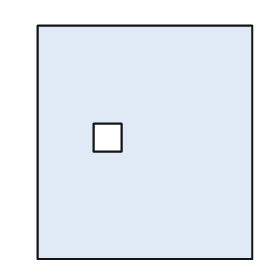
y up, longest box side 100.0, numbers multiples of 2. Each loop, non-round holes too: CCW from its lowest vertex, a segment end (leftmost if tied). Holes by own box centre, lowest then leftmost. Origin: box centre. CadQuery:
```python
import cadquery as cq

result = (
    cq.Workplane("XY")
    .moveTo(-46.0, -50.0)
    .lineTo(46.0, -50.0)
    .lineTo(46.0, 50.0)
    .lineTo(-46.0, 50.0)
    .close()
    .moveTo(-22.0, -4.0)
    .lineTo(-10.0, -4.0)
    .lineTo(-10.0, 8.0)
    .lineTo(-22.0, 8.0)
    .close()
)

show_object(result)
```